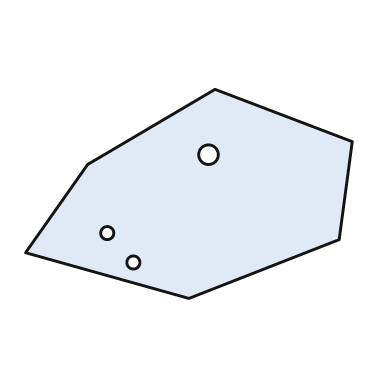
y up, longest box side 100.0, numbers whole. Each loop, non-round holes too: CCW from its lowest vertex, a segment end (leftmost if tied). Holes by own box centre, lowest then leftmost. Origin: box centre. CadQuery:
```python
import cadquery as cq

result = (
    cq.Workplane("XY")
    .moveTo(0.0, -32.0)
    .lineTo(46.0, -14.0)
    .lineTo(50.0, 16.0)
    .lineTo(8.0, 32.0)
    .lineTo(-31.0, 9.0)
    .lineTo(-50.0, -18.0)
    .close()
    .moveTo(-17.0, -21.0)
    .circle(2.0)
    .moveTo(-25.0, -12.0)
    .circle(2.0)
    .moveTo(6.0, 12.0)
    .circle(3.0)
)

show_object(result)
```